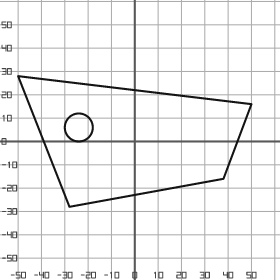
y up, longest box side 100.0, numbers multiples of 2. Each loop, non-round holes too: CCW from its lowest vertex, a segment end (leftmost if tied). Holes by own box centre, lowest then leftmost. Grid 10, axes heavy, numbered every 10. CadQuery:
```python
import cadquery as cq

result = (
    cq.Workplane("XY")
    .moveTo(-28.0, -28.0)
    .lineTo(38.0, -16.0)
    .lineTo(50.0, 16.0)
    .lineTo(-50.0, 28.0)
    .close()
    .moveTo(-24.0, 6.0)
    .circle(6.0)
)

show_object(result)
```